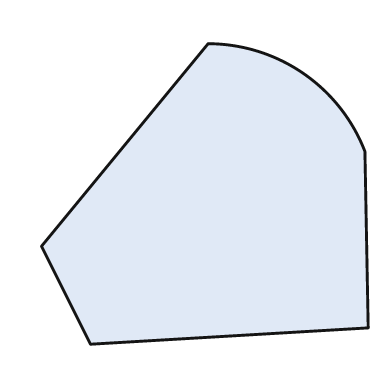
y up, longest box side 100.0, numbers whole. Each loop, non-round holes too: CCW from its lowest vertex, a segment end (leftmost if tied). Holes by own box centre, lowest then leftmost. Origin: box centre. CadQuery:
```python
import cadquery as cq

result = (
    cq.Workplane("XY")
    .moveTo(-35.0, -46.0)
    .lineTo(50.0, -41.0)
    .lineTo(49.0, 13.0)
    .threePointArc((30.0, 37.0), (1.0, 46.0))
    .lineTo(-50.0, -16.0)
    .close()
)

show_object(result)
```